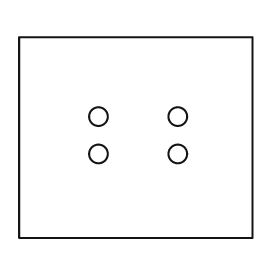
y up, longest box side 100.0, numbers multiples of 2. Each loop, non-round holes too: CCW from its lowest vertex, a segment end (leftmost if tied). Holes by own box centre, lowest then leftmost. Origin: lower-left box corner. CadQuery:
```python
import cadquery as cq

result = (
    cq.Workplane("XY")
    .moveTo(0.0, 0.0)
    .lineTo(100.0, 0.0)
    .lineTo(100.0, 86.0)
    .lineTo(0.0, 86.0)
    .close()
    .moveTo(34.0, 36.0)
    .circle(4.0)
    .moveTo(68.0, 36.0)
    .circle(4.0)
    .moveTo(34.0, 52.0)
    .circle(4.0)
    .moveTo(68.0, 52.0)
    .circle(4.0)
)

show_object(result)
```